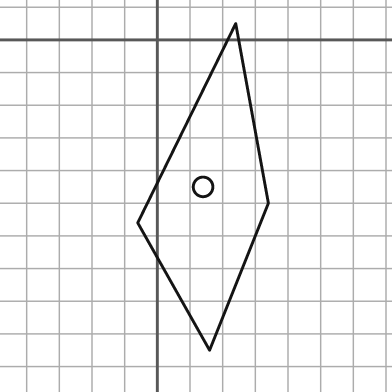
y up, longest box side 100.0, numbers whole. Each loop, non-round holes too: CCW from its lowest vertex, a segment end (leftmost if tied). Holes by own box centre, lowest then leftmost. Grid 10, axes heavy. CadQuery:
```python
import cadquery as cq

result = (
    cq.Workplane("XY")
    .moveTo(16.0, -95.0)
    .lineTo(34.0, -50.0)
    .lineTo(24.0, 5.0)
    .lineTo(-6.0, -56.0)
    .close()
    .moveTo(14.0, -45.0)
    .circle(3.0)
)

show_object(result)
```